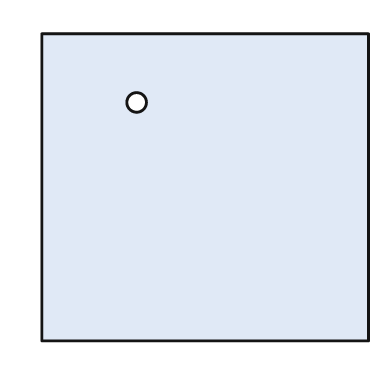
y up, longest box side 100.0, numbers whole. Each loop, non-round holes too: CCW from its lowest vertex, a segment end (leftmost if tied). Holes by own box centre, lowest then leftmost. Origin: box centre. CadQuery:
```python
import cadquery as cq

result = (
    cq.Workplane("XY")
    .moveTo(-50.0, -47.0)
    .lineTo(50.0, -47.0)
    .lineTo(50.0, 47.0)
    .lineTo(-50.0, 47.0)
    .close()
    .moveTo(-21.0, 26.0)
    .circle(3.0)
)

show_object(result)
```